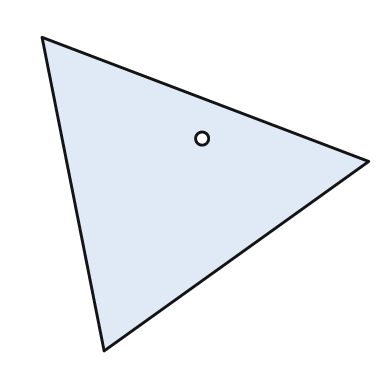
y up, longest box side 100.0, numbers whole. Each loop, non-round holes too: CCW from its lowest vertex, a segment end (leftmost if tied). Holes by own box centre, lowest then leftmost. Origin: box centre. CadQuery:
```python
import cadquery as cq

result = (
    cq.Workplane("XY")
    .moveTo(-31.0, -48.0)
    .lineTo(50.0, 10.0)
    .lineTo(-50.0, 48.0)
    .close()
    .moveTo(-1.0, 17.0)
    .circle(2.0)
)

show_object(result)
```